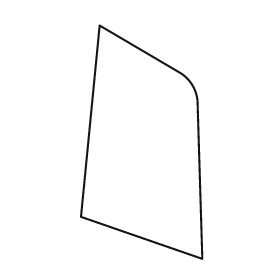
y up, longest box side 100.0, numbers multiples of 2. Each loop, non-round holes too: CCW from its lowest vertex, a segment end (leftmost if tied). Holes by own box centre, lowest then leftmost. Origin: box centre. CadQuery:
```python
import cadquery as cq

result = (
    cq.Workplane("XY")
    .moveTo(26.0, -50.0)
    .lineTo(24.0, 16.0)
    .threePointArc((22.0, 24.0), (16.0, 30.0))
    .lineTo(-18.0, 50.0)
    .lineTo(-26.0, -32.0)
    .close()
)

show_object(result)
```